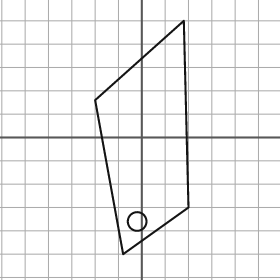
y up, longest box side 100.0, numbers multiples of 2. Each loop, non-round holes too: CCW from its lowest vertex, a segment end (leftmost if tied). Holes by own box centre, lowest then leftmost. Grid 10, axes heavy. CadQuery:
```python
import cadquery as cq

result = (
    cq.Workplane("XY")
    .moveTo(-8.0, -50.0)
    .lineTo(20.0, -30.0)
    .lineTo(18.0, 50.0)
    .lineTo(-20.0, 16.0)
    .close()
    .moveTo(-2.0, -36.0)
    .circle(4.0)
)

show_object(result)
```